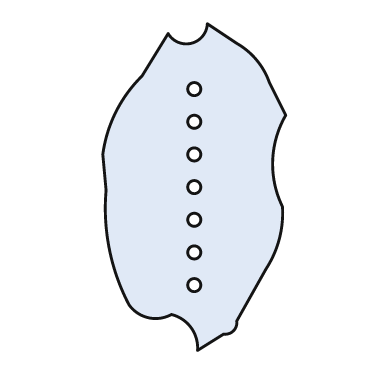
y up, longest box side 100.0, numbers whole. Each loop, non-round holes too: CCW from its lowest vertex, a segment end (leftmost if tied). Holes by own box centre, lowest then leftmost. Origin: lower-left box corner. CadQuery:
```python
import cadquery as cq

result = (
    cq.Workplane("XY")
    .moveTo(29.0, 0.0)
    .lineTo(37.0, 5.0)
    .threePointArc((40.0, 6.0), (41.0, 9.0))
    .lineTo(50.0, 25.0)
    .threePointArc((54.0, 34.0), (55.0, 44.0))
    .threePointArc((52.0, 58.0), (56.0, 72.0))
    .lineTo(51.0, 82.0)
    .threePointArc((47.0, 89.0), (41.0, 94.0))
    .lineTo(32.0, 100.0)
    .threePointArc((27.0, 94.0), (20.0, 97.0))
    .lineTo(12.0, 84.0)
    .threePointArc((4.0, 73.0), (0.0, 60.0))
    .lineTo(1.0, 49.0)
    .threePointArc((2.0, 31.0), (8.0, 14.0))
    .threePointArc((14.0, 10.0), (21.0, 11.0))
    .threePointArc((27.0, 7.0), (29.0, 0.0))
    .close()
    .moveTo(28.0, 20.0)
    .circle(2.0)
    .moveTo(28.0, 30.0)
    .circle(2.0)
    .moveTo(28.0, 40.0)
    .circle(2.0)
    .moveTo(28.0, 50.0)
    .circle(2.0)
    .moveTo(28.0, 60.0)
    .circle(2.0)
    .moveTo(28.0, 70.0)
    .circle(2.0)
    .moveTo(28.0, 80.0)
    .circle(2.0)
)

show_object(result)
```